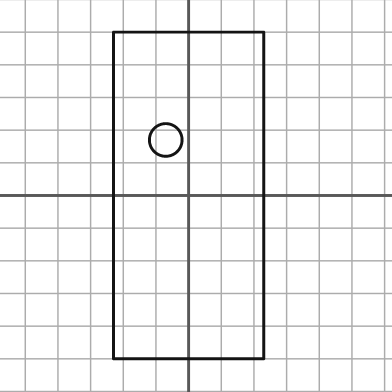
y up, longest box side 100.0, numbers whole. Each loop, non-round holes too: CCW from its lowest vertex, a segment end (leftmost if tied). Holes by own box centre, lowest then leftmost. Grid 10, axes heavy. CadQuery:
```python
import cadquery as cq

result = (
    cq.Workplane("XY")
    .moveTo(-23.0, -50.0)
    .lineTo(23.0, -50.0)
    .lineTo(23.0, 50.0)
    .lineTo(-23.0, 50.0)
    .close()
    .moveTo(-7.0, 17.0)
    .circle(5.0)
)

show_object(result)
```